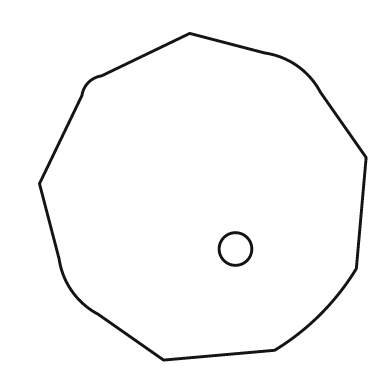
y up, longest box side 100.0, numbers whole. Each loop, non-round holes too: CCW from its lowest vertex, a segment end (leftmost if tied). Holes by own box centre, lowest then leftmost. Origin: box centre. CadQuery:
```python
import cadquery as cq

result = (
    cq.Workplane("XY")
    .moveTo(-12.0, -50.0)
    .lineTo(22.0, -47.0)
    .threePointArc((36.0, -36.0), (47.0, -22.0))
    .lineTo(50.0, 12.0)
    .lineTo(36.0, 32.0)
    .threePointArc((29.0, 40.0), (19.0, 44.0))
    .lineTo(-4.0, 50.0)
    .lineTo(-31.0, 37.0)
    .threePointArc((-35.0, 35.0), (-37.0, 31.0))
    .lineTo(-50.0, 4.0)
    .lineTo(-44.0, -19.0)
    .threePointArc((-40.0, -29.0), (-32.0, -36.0))
    .close()
    .moveTo(10.0, -16.0)
    .circle(5.0)
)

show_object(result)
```